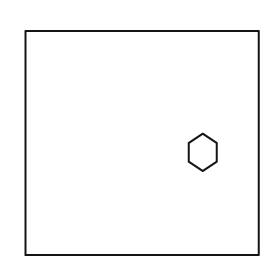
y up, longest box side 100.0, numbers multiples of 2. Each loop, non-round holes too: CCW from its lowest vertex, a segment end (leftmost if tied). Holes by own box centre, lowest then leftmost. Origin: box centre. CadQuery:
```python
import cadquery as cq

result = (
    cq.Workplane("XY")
    .moveTo(-50.0, -48.0)
    .lineTo(50.0, -48.0)
    .lineTo(50.0, 48.0)
    .lineTo(-50.0, 48.0)
    .close()
    .moveTo(26.0, -12.0)
    .lineTo(32.0, -8.0)
    .lineTo(32.0, 0.0)
    .lineTo(26.0, 4.0)
    .lineTo(20.0, 0.0)
    .lineTo(20.0, -8.0)
    .close()
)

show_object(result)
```